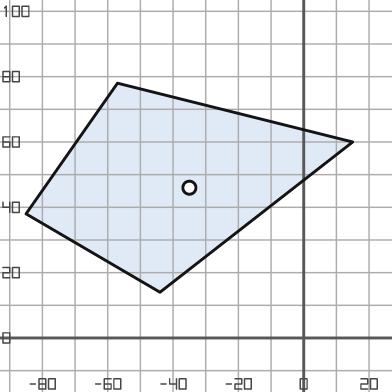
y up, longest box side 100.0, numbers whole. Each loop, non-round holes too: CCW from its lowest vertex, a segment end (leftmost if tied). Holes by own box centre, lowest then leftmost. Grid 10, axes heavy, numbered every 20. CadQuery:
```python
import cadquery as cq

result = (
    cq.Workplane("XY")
    .moveTo(-44.0, 14.0)
    .lineTo(15.0, 60.0)
    .lineTo(-57.0, 78.0)
    .lineTo(-85.0, 38.0)
    .close()
    .moveTo(-35.0, 46.0)
    .circle(2.0)
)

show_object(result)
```